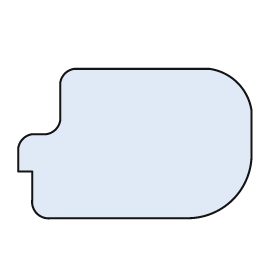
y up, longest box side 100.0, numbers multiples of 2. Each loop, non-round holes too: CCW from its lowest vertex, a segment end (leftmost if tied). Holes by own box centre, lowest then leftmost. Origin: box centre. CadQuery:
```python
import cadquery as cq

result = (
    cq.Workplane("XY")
    .moveTo(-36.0, -32.0)
    .lineTo(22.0, -32.0)
    .threePointArc((42.0, -24.0), (50.0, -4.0))
    .lineTo(50.0, 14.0)
    .threePointArc((44.0, 26.0), (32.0, 32.0))
    .lineTo(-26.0, 32.0)
    .threePointArc((-30.0, 30.0), (-32.0, 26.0))
    .lineTo(-32.0, 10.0)
    .threePointArc((-34.0, 6.0), (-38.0, 4.0))
    .lineTo(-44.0, 4.0)
    .threePointArc((-48.0, 2.0), (-50.0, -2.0))
    .lineTo(-50.0, -12.0)
    .lineTo(-44.0, -12.0)
    .lineTo(-44.0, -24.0)
    .threePointArc((-42.0, -30.0), (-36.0, -32.0))
    .close()
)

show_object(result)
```